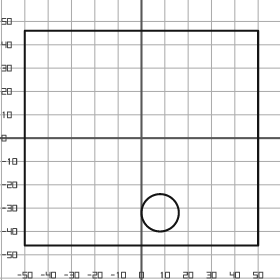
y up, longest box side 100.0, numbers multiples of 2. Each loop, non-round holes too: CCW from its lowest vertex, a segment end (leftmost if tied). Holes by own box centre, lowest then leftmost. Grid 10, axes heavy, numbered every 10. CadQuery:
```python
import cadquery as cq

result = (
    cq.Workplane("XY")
    .moveTo(-50.0, -46.0)
    .lineTo(50.0, -46.0)
    .lineTo(50.0, 46.0)
    .lineTo(-50.0, 46.0)
    .close()
    .moveTo(8.0, -32.0)
    .circle(8.0)
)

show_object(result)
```